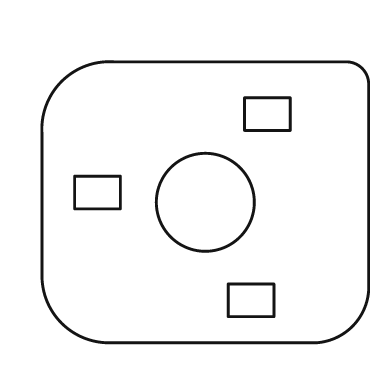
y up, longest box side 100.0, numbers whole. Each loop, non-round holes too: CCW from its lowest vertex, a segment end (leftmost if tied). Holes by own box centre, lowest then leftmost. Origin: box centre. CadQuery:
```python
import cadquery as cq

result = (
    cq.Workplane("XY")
    .moveTo(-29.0, -43.0)
    .lineTo(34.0, -43.0)
    .threePointArc((45.0, -38.0), (50.0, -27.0))
    .lineTo(50.0, 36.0)
    .threePointArc((48.0, 41.0), (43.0, 43.0))
    .lineTo(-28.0, 43.0)
    .threePointArc((-44.0, 37.0), (-50.0, 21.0))
    .lineTo(-50.0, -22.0)
    .threePointArc((-44.0, -37.0), (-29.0, -43.0))
    .close()
    .moveTo(7.0, -35.0)
    .lineTo(21.0, -35.0)
    .lineTo(21.0, -25.0)
    .lineTo(7.0, -25.0)
    .close()
    .moveTo(0.0, 0.0)
    .circle(15.0)
    .moveTo(-40.0, -2.0)
    .lineTo(-26.0, -2.0)
    .lineTo(-26.0, 8.0)
    .lineTo(-40.0, 8.0)
    .close()
    .moveTo(12.0, 22.0)
    .lineTo(26.0, 22.0)
    .lineTo(26.0, 32.0)
    .lineTo(12.0, 32.0)
    .close()
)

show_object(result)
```